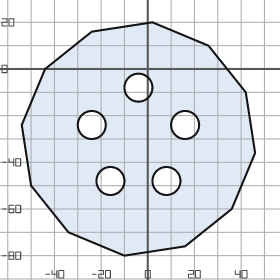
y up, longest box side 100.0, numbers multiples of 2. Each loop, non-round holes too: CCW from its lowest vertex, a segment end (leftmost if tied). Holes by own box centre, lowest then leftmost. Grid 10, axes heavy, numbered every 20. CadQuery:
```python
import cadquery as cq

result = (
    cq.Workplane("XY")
    .moveTo(-10.0, -80.0)
    .lineTo(16.0, -76.0)
    .lineTo(36.0, -60.0)
    .lineTo(46.0, -36.0)
    .lineTo(42.0, -10.0)
    .lineTo(26.0, 10.0)
    .lineTo(2.0, 20.0)
    .lineTo(-24.0, 16.0)
    .lineTo(-44.0, 0.0)
    .lineTo(-54.0, -24.0)
    .lineTo(-50.0, -50.0)
    .lineTo(-34.0, -70.0)
    .close()
    .moveTo(-16.0, -48.0)
    .circle(6.0)
    .moveTo(8.0, -48.0)
    .circle(6.0)
    .moveTo(-24.0, -24.0)
    .circle(6.0)
    .moveTo(16.0, -24.0)
    .circle(6.0)
    .moveTo(-4.0, -8.0)
    .circle(6.0)
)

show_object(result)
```